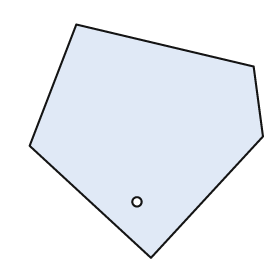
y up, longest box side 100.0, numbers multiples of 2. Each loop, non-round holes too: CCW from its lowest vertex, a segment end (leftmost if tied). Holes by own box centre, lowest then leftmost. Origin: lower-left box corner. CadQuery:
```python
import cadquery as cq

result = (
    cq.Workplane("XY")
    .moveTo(52.0, 0.0)
    .lineTo(100.0, 52.0)
    .lineTo(96.0, 82.0)
    .lineTo(20.0, 100.0)
    .lineTo(0.0, 48.0)
    .close()
    .moveTo(46.0, 24.0)
    .circle(2.0)
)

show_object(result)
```